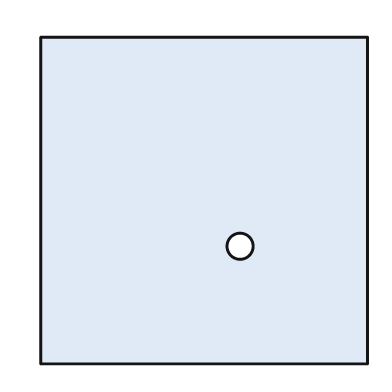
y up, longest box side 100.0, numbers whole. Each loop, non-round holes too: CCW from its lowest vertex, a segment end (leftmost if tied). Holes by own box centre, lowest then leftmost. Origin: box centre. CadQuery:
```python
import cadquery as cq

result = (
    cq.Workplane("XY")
    .moveTo(-50.0, -50.0)
    .lineTo(50.0, -50.0)
    .lineTo(50.0, 50.0)
    .lineTo(-50.0, 50.0)
    .close()
    .moveTo(11.0, -14.0)
    .circle(4.0)
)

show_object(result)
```